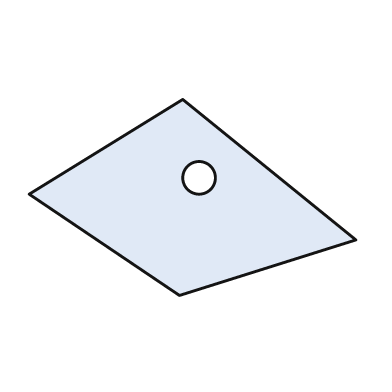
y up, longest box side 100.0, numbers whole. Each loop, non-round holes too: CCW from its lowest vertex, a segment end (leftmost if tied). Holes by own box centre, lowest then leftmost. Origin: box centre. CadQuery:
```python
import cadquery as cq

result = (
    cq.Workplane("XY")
    .moveTo(-4.0, -30.0)
    .lineTo(50.0, -13.0)
    .lineTo(-3.0, 30.0)
    .lineTo(-50.0, 1.0)
    .close()
    .moveTo(2.0, 6.0)
    .circle(5.0)
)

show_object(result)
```